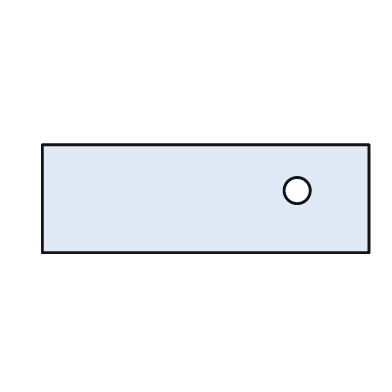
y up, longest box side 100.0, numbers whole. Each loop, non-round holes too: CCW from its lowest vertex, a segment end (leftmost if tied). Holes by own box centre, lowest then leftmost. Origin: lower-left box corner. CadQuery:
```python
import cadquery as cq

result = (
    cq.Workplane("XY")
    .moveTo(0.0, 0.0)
    .lineTo(100.0, 0.0)
    .lineTo(100.0, 33.0)
    .lineTo(0.0, 33.0)
    .close()
    .moveTo(78.0, 19.0)
    .circle(4.0)
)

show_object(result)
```